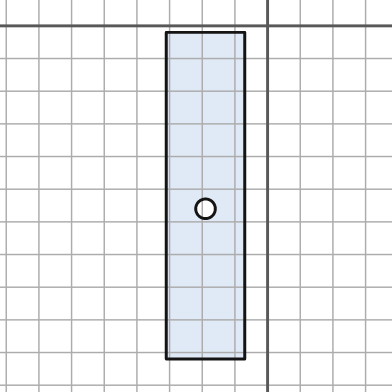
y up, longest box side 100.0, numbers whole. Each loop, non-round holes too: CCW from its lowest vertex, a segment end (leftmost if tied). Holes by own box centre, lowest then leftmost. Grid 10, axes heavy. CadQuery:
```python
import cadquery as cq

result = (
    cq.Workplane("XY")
    .moveTo(-31.0, -102.0)
    .lineTo(-7.0, -102.0)
    .lineTo(-7.0, -2.0)
    .lineTo(-31.0, -2.0)
    .close()
    .moveTo(-19.0, -56.0)
    .circle(3.0)
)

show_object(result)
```